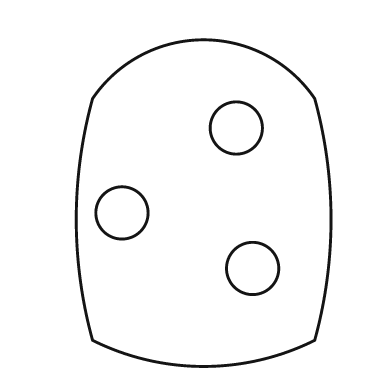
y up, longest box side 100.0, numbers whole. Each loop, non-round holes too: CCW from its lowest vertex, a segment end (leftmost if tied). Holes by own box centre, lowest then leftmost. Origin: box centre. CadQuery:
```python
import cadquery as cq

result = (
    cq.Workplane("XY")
    .moveTo(-34.0, -42.0)
    .threePointArc((0.0, -50.0), (34.0, -42.0))
    .threePointArc((39.0, -5.0), (34.0, 32.0))
    .threePointArc((0.0, 50.0), (-34.0, 32.0))
    .threePointArc((-39.0, -5.0), (-34.0, -42.0))
    .close()
    .moveTo(15.0, -20.0)
    .circle(8.0)
    .moveTo(-25.0, -3.0)
    .circle(8.0)
    .moveTo(10.0, 23.0)
    .circle(8.0)
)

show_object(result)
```